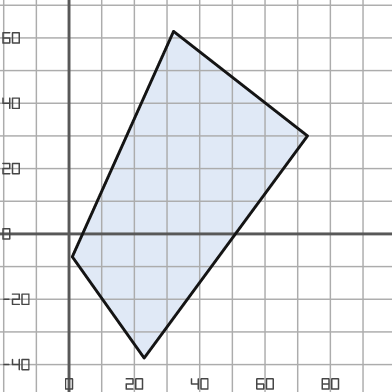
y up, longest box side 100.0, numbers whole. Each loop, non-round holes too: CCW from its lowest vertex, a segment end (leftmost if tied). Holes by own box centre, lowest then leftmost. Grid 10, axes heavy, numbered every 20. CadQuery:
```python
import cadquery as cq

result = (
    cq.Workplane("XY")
    .moveTo(23.0, -38.0)
    .lineTo(73.0, 30.0)
    .lineTo(32.0, 62.0)
    .lineTo(1.0, -7.0)
    .close()
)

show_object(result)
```